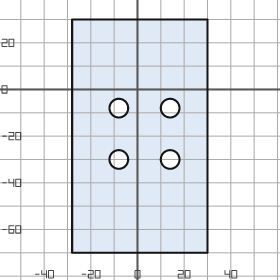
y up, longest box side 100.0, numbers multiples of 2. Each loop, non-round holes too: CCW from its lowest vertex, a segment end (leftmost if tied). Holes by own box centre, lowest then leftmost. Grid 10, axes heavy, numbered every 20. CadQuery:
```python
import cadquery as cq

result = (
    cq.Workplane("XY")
    .moveTo(-28.0, -70.0)
    .lineTo(30.0, -70.0)
    .lineTo(30.0, 30.0)
    .lineTo(-28.0, 30.0)
    .close()
    .moveTo(-8.0, -30.0)
    .circle(4.0)
    .moveTo(14.0, -30.0)
    .circle(4.0)
    .moveTo(-8.0, -8.0)
    .circle(4.0)
    .moveTo(14.0, -8.0)
    .circle(4.0)
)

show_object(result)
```